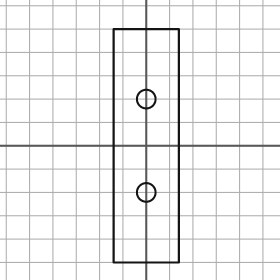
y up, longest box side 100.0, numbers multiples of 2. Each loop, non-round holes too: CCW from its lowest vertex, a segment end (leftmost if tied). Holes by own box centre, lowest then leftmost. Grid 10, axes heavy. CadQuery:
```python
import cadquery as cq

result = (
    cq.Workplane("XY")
    .moveTo(-14.0, -50.0)
    .lineTo(14.0, -50.0)
    .lineTo(14.0, 50.0)
    .lineTo(-14.0, 50.0)
    .close()
    .moveTo(0.0, -20.0)
    .circle(4.0)
    .moveTo(0.0, 20.0)
    .circle(4.0)
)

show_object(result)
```